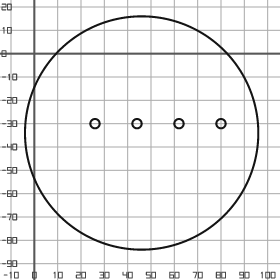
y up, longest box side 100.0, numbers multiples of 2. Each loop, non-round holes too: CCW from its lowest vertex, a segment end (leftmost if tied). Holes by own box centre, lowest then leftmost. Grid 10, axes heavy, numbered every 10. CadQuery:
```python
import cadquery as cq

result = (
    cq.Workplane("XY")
    .moveTo(46.0, -34.0)
    .circle(50.0)
    .moveTo(26.0, -30.0)
    .circle(2.0)
    .moveTo(44.0, -30.0)
    .circle(2.0)
    .moveTo(62.0, -30.0)
    .circle(2.0)
    .moveTo(80.0, -30.0)
    .circle(2.0)
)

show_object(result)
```